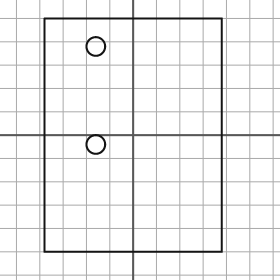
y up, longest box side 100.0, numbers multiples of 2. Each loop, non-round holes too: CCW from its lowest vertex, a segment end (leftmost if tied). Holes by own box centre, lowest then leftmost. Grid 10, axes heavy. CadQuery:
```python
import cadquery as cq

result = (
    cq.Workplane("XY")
    .moveTo(-38.0, -50.0)
    .lineTo(38.0, -50.0)
    .lineTo(38.0, 50.0)
    .lineTo(-38.0, 50.0)
    .close()
    .moveTo(-16.0, -4.0)
    .circle(4.0)
    .moveTo(-16.0, 38.0)
    .circle(4.0)
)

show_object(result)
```